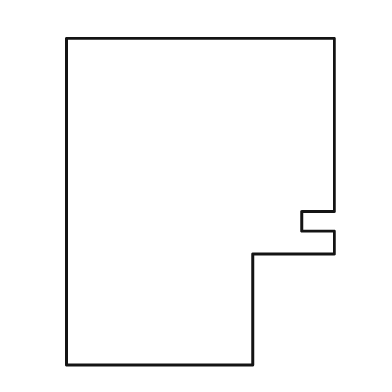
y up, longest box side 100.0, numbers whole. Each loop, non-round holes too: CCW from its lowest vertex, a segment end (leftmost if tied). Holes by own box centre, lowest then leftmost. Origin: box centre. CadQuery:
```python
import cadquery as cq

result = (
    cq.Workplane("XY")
    .moveTo(-41.0, -50.0)
    .lineTo(16.0, -50.0)
    .lineTo(16.0, -16.0)
    .lineTo(41.0, -16.0)
    .lineTo(41.0, -9.0)
    .lineTo(31.0, -9.0)
    .lineTo(31.0, -3.0)
    .lineTo(41.0, -3.0)
    .lineTo(41.0, 50.0)
    .lineTo(-41.0, 50.0)
    .close()
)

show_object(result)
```